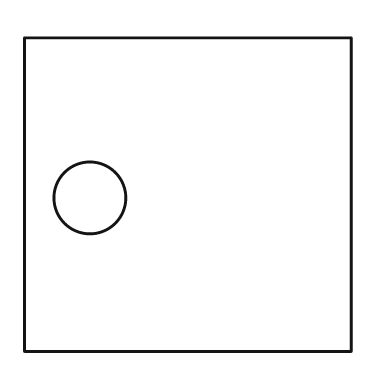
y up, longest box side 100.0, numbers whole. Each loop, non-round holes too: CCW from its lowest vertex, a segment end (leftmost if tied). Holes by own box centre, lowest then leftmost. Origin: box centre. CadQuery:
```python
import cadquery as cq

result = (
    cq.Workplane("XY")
    .moveTo(-50.0, -48.0)
    .lineTo(50.0, -48.0)
    .lineTo(50.0, 48.0)
    .lineTo(-50.0, 48.0)
    .close()
    .moveTo(-30.0, -1.0)
    .circle(11.0)
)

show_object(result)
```